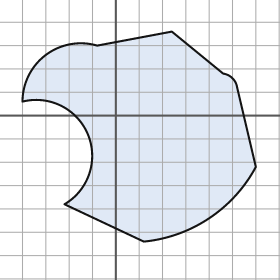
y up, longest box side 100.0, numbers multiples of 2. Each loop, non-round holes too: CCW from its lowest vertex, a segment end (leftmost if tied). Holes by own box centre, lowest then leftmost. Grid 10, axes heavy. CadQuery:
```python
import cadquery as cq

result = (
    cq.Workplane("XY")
    .moveTo(12.0, -54.0)
    .threePointArc((40.0, -44.0), (60.0, -22.0))
    .lineTo(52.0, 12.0)
    .threePointArc((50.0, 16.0), (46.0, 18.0))
    .lineTo(24.0, 36.0)
    .lineTo(-8.0, 30.0)
    .threePointArc((-30.0, 26.0), (-40.0, 6.0))
    .threePointArc((-12.0, -8.0), (-22.0, -38.0))
    .close()
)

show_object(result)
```